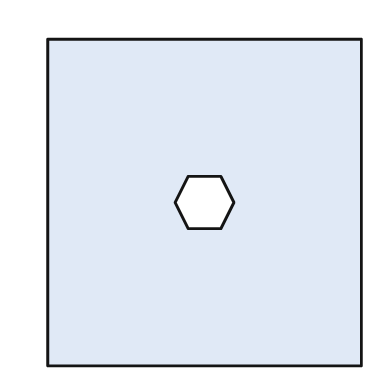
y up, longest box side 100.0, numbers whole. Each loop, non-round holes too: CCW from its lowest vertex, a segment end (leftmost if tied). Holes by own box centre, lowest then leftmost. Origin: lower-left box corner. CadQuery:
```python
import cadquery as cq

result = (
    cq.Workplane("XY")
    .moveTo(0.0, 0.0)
    .lineTo(96.0, 0.0)
    .lineTo(96.0, 100.0)
    .lineTo(0.0, 100.0)
    .close()
    .moveTo(43.0, 42.0)
    .lineTo(53.0, 42.0)
    .lineTo(57.0, 50.0)
    .lineTo(53.0, 58.0)
    .lineTo(43.0, 58.0)
    .lineTo(39.0, 50.0)
    .close()
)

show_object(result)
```